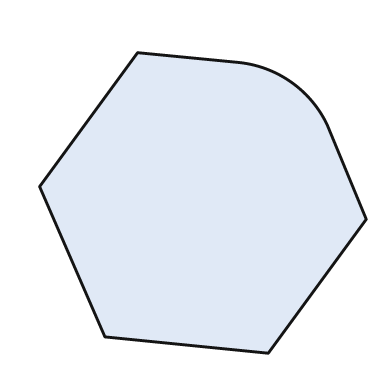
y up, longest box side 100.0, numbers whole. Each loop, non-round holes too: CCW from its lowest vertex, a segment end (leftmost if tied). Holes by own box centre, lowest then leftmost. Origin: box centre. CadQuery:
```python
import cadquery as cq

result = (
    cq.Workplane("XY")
    .moveTo(20.0, -46.0)
    .lineTo(50.0, -5.0)
    .lineTo(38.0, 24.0)
    .threePointArc((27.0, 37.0), (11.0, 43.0))
    .lineTo(-20.0, 46.0)
    .lineTo(-50.0, 5.0)
    .lineTo(-30.0, -41.0)
    .close()
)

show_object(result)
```